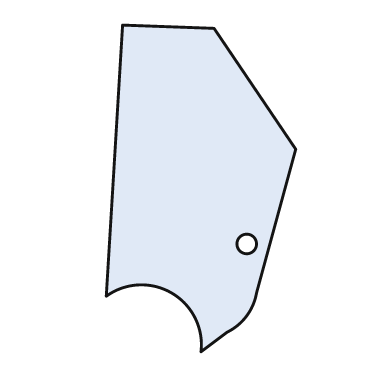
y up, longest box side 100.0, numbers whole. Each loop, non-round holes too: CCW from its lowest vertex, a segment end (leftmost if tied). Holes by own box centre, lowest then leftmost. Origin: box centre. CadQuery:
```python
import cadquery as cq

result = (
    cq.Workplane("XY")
    .moveTo(0.0, -50.0)
    .lineTo(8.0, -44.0)
    .threePointArc((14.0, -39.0), (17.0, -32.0))
    .lineTo(29.0, 12.0)
    .lineTo(4.0, 49.0)
    .lineTo(-24.0, 50.0)
    .lineTo(-29.0, -33.0)
    .threePointArc((-9.0, -32.0), (0.0, -50.0))
    .close()
    .moveTo(14.0, -17.0)
    .circle(3.0)
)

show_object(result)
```